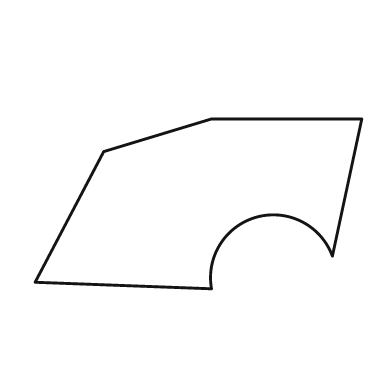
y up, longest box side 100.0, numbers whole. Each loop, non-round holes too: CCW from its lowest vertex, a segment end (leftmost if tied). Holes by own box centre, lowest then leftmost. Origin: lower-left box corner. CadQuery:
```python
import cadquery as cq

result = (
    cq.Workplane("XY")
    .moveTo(54.0, 0.0)
    .threePointArc((68.0, 22.0), (91.0, 10.0))
    .lineTo(100.0, 52.0)
    .lineTo(54.0, 52.0)
    .lineTo(21.0, 42.0)
    .lineTo(0.0, 2.0)
    .close()
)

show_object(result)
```